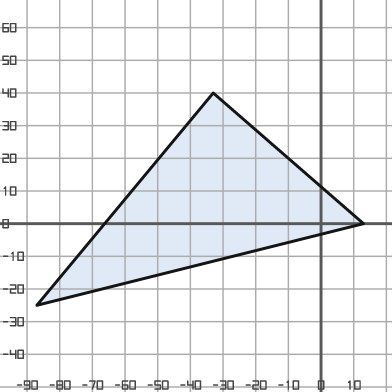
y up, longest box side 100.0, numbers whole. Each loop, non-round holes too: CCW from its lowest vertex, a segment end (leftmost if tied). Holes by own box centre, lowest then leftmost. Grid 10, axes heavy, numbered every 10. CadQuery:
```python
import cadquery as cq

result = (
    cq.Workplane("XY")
    .moveTo(-87.0, -25.0)
    .lineTo(13.0, 0.0)
    .lineTo(-33.0, 40.0)
    .close()
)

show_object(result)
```